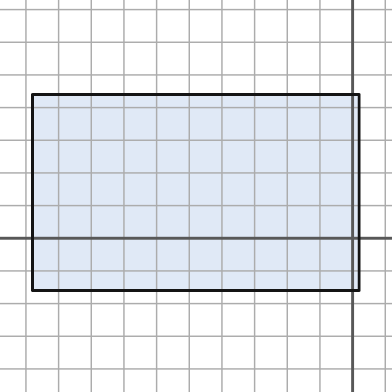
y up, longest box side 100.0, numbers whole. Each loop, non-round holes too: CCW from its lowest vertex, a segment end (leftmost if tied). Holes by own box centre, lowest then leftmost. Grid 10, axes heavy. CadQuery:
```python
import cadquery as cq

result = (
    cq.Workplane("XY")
    .moveTo(-98.0, -16.0)
    .lineTo(2.0, -16.0)
    .lineTo(2.0, 44.0)
    .lineTo(-98.0, 44.0)
    .close()
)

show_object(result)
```